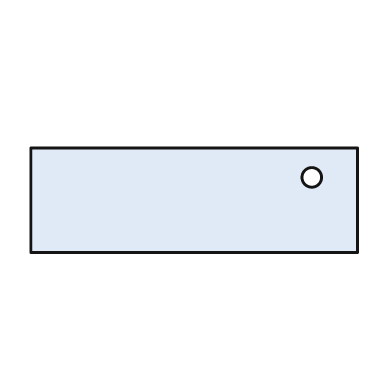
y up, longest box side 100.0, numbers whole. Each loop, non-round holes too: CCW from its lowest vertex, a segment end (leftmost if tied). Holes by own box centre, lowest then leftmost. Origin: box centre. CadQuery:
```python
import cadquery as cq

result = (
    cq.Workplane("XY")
    .moveTo(-50.0, -16.0)
    .lineTo(50.0, -16.0)
    .lineTo(50.0, 16.0)
    .lineTo(-50.0, 16.0)
    .close()
    .moveTo(36.0, 7.0)
    .circle(3.0)
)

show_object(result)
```